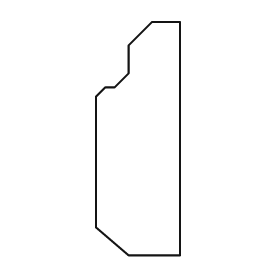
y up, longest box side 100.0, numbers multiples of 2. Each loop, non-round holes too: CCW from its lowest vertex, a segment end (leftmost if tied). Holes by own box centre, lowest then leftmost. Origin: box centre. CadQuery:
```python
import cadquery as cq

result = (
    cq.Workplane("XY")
    .moveTo(-4.0, -50.0)
    .lineTo(18.0, -50.0)
    .lineTo(18.0, 50.0)
    .lineTo(6.0, 50.0)
    .lineTo(-4.0, 40.0)
    .lineTo(-4.0, 28.0)
    .lineTo(-10.0, 22.0)
    .lineTo(-14.0, 22.0)
    .lineTo(-18.0, 18.0)
    .lineTo(-18.0, -38.0)
    .close()
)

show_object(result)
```